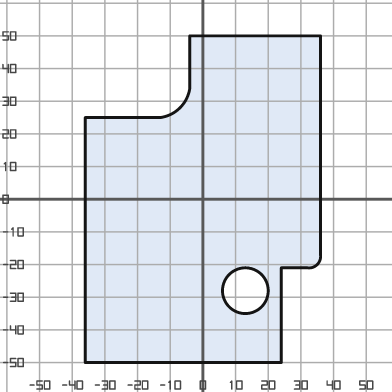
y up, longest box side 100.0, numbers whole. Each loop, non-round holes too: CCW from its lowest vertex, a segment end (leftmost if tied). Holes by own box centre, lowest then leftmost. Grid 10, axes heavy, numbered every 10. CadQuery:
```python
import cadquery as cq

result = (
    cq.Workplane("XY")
    .moveTo(-36.0, -50.0)
    .lineTo(24.0, -50.0)
    .lineTo(24.0, -21.0)
    .lineTo(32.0, -21.0)
    .threePointArc((35.0, -20.0), (36.0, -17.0))
    .lineTo(36.0, 50.0)
    .lineTo(-4.0, 50.0)
    .lineTo(-4.0, 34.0)
    .threePointArc((-7.0, 28.0), (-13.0, 25.0))
    .lineTo(-36.0, 25.0)
    .close()
    .moveTo(13.0, -28.0)
    .circle(7.0)
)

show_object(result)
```